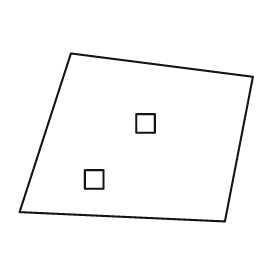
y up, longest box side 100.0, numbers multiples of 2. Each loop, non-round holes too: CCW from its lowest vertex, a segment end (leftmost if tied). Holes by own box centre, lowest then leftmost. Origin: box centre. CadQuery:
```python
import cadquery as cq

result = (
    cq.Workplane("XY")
    .moveTo(38.0, -36.0)
    .lineTo(50.0, 26.0)
    .lineTo(-28.0, 36.0)
    .lineTo(-50.0, -32.0)
    .close()
    .moveTo(-22.0, -22.0)
    .lineTo(-14.0, -22.0)
    .lineTo(-14.0, -14.0)
    .lineTo(-22.0, -14.0)
    .close()
    .moveTo(0.0, 2.0)
    .lineTo(8.0, 2.0)
    .lineTo(8.0, 10.0)
    .lineTo(0.0, 10.0)
    .close()
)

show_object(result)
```